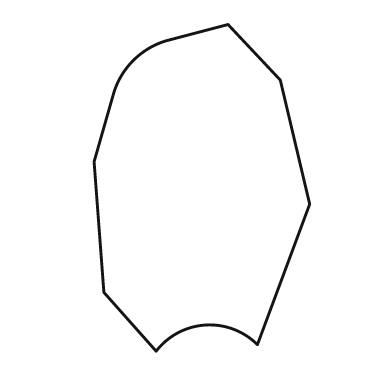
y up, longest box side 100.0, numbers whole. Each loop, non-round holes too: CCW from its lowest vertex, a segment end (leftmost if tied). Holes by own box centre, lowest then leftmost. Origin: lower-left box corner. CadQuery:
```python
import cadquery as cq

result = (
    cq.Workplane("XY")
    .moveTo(19.0, 0.0)
    .threePointArc((34.0, 8.0), (50.0, 2.0))
    .lineTo(66.0, 45.0)
    .lineTo(57.0, 83.0)
    .lineTo(41.0, 100.0)
    .lineTo(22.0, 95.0)
    .threePointArc((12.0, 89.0), (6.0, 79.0))
    .lineTo(0.0, 58.0)
    .lineTo(3.0, 18.0)
    .close()
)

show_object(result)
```